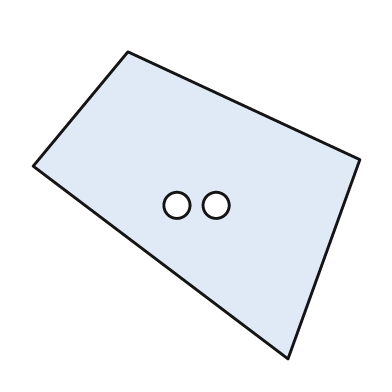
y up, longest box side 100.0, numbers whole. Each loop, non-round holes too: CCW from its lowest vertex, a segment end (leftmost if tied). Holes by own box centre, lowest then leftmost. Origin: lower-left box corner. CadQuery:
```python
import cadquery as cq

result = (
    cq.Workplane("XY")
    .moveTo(78.0, 0.0)
    .lineTo(100.0, 61.0)
    .lineTo(29.0, 94.0)
    .lineTo(0.0, 59.0)
    .close()
    .moveTo(44.0, 47.0)
    .circle(4.0)
    .moveTo(56.0, 47.0)
    .circle(4.0)
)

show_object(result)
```